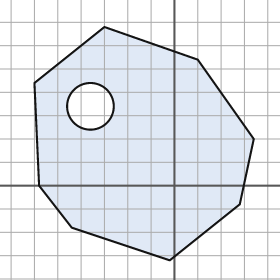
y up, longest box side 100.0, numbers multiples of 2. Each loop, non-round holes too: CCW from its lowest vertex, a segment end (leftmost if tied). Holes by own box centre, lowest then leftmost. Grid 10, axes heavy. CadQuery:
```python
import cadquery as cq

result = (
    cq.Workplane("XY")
    .moveTo(-2.0, -32.0)
    .lineTo(28.0, -8.0)
    .lineTo(34.0, 20.0)
    .lineTo(10.0, 54.0)
    .lineTo(-30.0, 68.0)
    .lineTo(-60.0, 44.0)
    .lineTo(-58.0, 0.0)
    .lineTo(-44.0, -18.0)
    .close()
    .moveTo(-36.0, 34.0)
    .circle(10.0)
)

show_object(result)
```